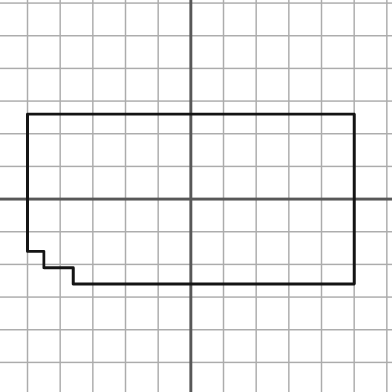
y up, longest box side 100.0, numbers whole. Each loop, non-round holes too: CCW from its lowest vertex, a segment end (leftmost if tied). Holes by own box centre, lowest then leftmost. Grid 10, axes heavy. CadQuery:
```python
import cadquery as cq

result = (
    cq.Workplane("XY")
    .moveTo(-36.0, -26.0)
    .lineTo(50.0, -26.0)
    .lineTo(50.0, 26.0)
    .lineTo(-50.0, 26.0)
    .lineTo(-50.0, -16.0)
    .lineTo(-45.0, -16.0)
    .lineTo(-45.0, -21.0)
    .lineTo(-36.0, -21.0)
    .close()
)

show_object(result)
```